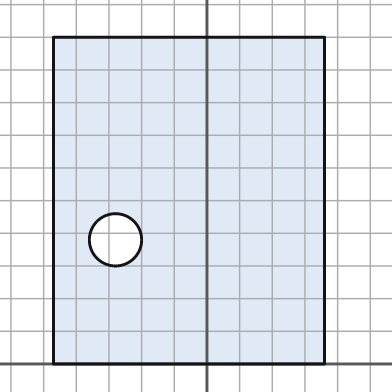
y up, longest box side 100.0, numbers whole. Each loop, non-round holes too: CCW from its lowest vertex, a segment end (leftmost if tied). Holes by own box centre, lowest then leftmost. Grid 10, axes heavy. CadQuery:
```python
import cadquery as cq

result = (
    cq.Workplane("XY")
    .moveTo(-47.0, 0.0)
    .lineTo(36.0, 0.0)
    .lineTo(36.0, 100.0)
    .lineTo(-47.0, 100.0)
    .close()
    .moveTo(-28.0, 38.0)
    .circle(8.0)
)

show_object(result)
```